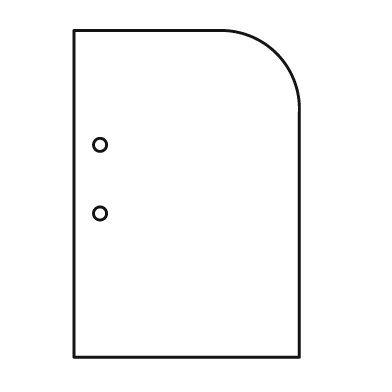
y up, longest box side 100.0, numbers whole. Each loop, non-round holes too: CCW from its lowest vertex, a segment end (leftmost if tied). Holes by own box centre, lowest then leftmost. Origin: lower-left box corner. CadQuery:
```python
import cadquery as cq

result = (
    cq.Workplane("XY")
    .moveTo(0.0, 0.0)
    .lineTo(69.0, 0.0)
    .lineTo(69.0, 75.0)
    .threePointArc((62.0, 93.0), (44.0, 100.0))
    .lineTo(0.0, 100.0)
    .close()
    .moveTo(8.0, 44.0)
    .circle(2.0)
    .moveTo(8.0, 65.0)
    .circle(2.0)
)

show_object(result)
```